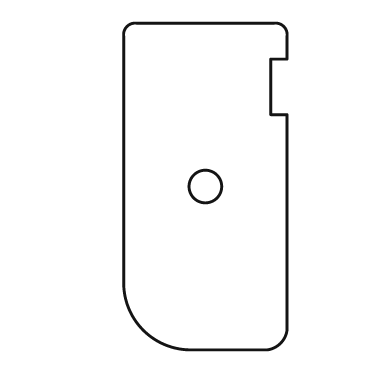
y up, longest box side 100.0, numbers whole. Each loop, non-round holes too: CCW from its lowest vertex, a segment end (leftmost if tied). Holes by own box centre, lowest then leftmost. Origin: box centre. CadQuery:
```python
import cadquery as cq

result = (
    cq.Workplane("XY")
    .moveTo(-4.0, -50.0)
    .lineTo(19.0, -50.0)
    .threePointArc((23.0, -48.0), (25.0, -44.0))
    .lineTo(25.0, 22.0)
    .lineTo(20.0, 22.0)
    .lineTo(20.0, 39.0)
    .lineTo(25.0, 39.0)
    .lineTo(25.0, 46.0)
    .threePointArc((24.0, 49.0), (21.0, 50.0))
    .lineTo(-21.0, 50.0)
    .threePointArc((-24.0, 49.0), (-25.0, 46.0))
    .lineTo(-25.0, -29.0)
    .threePointArc((-19.0, -44.0), (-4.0, -50.0))
    .close()
    .moveTo(0.0, 0.0)
    .circle(5.0)
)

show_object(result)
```